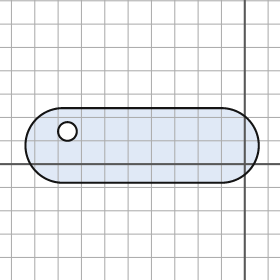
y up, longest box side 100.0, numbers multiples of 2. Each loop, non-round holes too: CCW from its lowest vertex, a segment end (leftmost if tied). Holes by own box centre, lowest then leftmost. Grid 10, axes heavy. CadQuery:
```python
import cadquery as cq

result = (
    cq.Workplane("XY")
    .moveTo(-78.0, -8.0)
    .lineTo(-10.0, -8.0)
    .threePointArc((6.0, 8.0), (-10.0, 24.0))
    .lineTo(-78.0, 24.0)
    .threePointArc((-94.0, 8.0), (-78.0, -8.0))
    .close()
    .moveTo(-76.0, 14.0)
    .circle(4.0)
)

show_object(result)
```